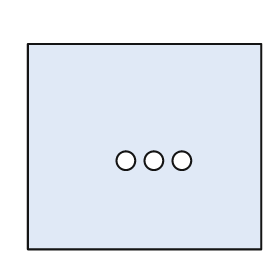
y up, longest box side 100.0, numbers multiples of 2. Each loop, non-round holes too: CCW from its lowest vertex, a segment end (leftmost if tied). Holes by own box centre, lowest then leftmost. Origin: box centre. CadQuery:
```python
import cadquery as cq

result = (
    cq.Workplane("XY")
    .moveTo(-50.0, -44.0)
    .lineTo(50.0, -44.0)
    .lineTo(50.0, 44.0)
    .lineTo(-50.0, 44.0)
    .close()
    .moveTo(-8.0, -6.0)
    .circle(4.0)
    .moveTo(4.0, -6.0)
    .circle(4.0)
    .moveTo(16.0, -6.0)
    .circle(4.0)
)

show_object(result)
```